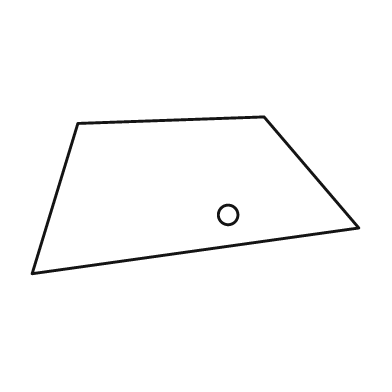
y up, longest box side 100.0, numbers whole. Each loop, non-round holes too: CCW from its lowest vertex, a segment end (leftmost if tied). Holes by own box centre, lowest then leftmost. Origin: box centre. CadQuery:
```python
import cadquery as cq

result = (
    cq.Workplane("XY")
    .moveTo(-50.0, -24.0)
    .lineTo(50.0, -10.0)
    .lineTo(21.0, 24.0)
    .lineTo(-36.0, 22.0)
    .close()
    .moveTo(10.0, -6.0)
    .circle(3.0)
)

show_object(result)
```